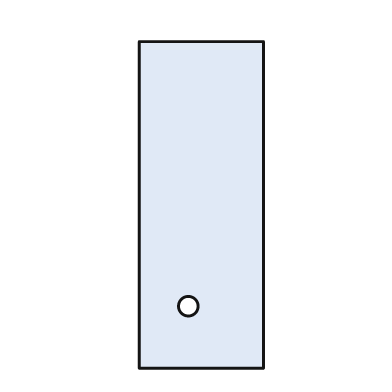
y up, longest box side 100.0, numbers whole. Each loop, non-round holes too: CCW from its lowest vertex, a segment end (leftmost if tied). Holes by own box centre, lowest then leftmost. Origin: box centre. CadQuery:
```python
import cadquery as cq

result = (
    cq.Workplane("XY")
    .moveTo(-19.0, -50.0)
    .lineTo(19.0, -50.0)
    .lineTo(19.0, 50.0)
    .lineTo(-19.0, 50.0)
    .close()
    .moveTo(-4.0, -31.0)
    .circle(3.0)
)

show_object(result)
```